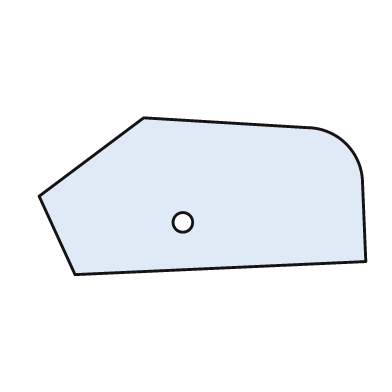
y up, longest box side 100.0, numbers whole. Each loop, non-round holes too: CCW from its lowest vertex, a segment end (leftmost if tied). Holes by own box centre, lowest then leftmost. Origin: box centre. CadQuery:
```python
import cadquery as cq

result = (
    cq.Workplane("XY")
    .moveTo(-39.0, -24.0)
    .lineTo(50.0, -20.0)
    .lineTo(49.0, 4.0)
    .threePointArc((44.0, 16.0), (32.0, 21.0))
    .lineTo(-18.0, 24.0)
    .lineTo(-50.0, 0.0)
    .close()
    .moveTo(-6.0, -8.0)
    .circle(3.0)
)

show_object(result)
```